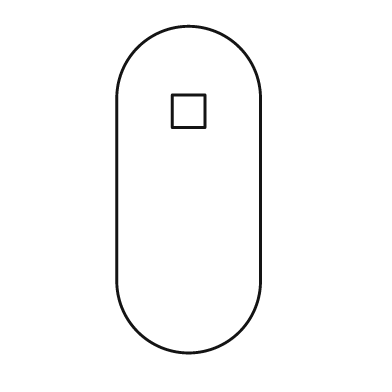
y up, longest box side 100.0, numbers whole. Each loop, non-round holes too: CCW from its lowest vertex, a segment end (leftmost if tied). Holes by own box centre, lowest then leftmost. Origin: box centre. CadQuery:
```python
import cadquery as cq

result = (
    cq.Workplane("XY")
    .moveTo(-22.0, -28.0)
    .threePointArc((0.0, -50.0), (22.0, -28.0))
    .lineTo(22.0, 28.0)
    .threePointArc((0.0, 50.0), (-22.0, 28.0))
    .close()
    .moveTo(-5.0, 19.0)
    .lineTo(5.0, 19.0)
    .lineTo(5.0, 29.0)
    .lineTo(-5.0, 29.0)
    .close()
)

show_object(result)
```